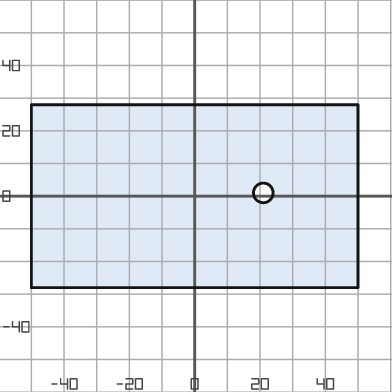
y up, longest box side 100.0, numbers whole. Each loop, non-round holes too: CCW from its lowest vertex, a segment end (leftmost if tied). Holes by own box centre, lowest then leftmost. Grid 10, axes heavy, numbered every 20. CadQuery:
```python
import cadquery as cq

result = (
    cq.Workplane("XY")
    .moveTo(-50.0, -28.0)
    .lineTo(50.0, -28.0)
    .lineTo(50.0, 28.0)
    .lineTo(-50.0, 28.0)
    .close()
    .moveTo(21.0, 1.0)
    .circle(3.0)
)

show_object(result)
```